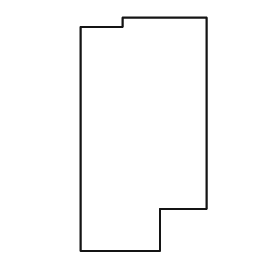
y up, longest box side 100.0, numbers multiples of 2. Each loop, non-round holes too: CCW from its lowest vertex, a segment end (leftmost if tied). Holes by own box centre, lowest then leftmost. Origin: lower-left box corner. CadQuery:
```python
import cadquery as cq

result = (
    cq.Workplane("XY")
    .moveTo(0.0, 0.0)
    .lineTo(34.0, 0.0)
    .lineTo(34.0, 18.0)
    .lineTo(54.0, 18.0)
    .lineTo(54.0, 100.0)
    .lineTo(18.0, 100.0)
    .lineTo(18.0, 96.0)
    .lineTo(0.0, 96.0)
    .close()
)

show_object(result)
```